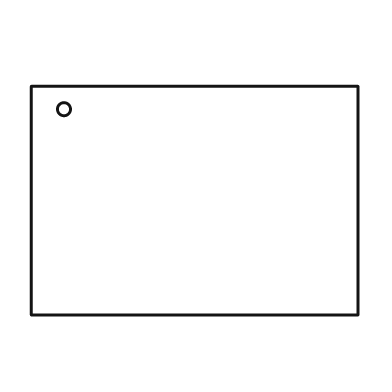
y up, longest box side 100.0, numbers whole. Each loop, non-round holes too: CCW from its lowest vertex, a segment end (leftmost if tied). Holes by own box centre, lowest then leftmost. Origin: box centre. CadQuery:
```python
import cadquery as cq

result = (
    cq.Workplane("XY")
    .moveTo(-50.0, -35.0)
    .lineTo(50.0, -35.0)
    .lineTo(50.0, 35.0)
    .lineTo(-50.0, 35.0)
    .close()
    .moveTo(-40.0, 28.0)
    .circle(2.0)
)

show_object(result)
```